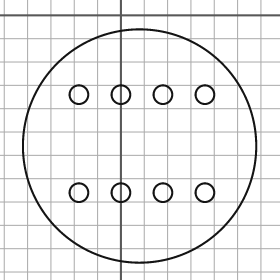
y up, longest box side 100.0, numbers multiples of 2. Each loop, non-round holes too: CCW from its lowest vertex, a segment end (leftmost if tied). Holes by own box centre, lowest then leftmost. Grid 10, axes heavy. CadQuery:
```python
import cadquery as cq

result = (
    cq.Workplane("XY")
    .moveTo(8.0, -56.0)
    .circle(50.0)
    .moveTo(-18.0, -76.0)
    .circle(4.0)
    .moveTo(0.0, -76.0)
    .circle(4.0)
    .moveTo(18.0, -76.0)
    .circle(4.0)
    .moveTo(36.0, -76.0)
    .circle(4.0)
    .moveTo(-18.0, -34.0)
    .circle(4.0)
    .moveTo(0.0, -34.0)
    .circle(4.0)
    .moveTo(18.0, -34.0)
    .circle(4.0)
    .moveTo(36.0, -34.0)
    .circle(4.0)
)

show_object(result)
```